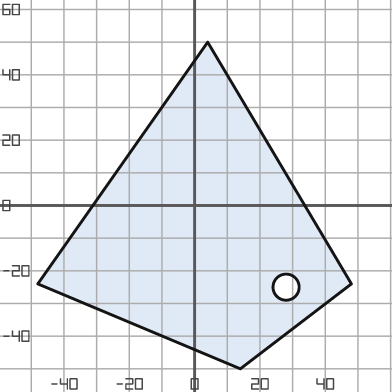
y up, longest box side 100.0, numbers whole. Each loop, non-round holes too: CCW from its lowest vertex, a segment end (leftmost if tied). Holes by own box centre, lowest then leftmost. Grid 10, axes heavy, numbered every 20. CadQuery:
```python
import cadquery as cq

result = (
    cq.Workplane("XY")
    .moveTo(14.0, -50.0)
    .lineTo(48.0, -24.0)
    .lineTo(4.0, 50.0)
    .lineTo(-48.0, -24.0)
    .close()
    .moveTo(28.0, -25.0)
    .circle(4.0)
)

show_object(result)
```